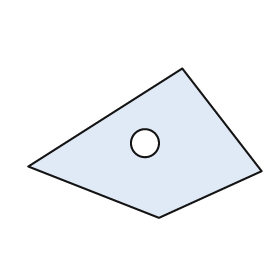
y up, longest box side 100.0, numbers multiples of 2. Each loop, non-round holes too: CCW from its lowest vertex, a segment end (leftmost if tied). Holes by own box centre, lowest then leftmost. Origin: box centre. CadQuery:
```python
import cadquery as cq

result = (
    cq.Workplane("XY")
    .moveTo(6.0, -32.0)
    .lineTo(50.0, -12.0)
    .lineTo(16.0, 32.0)
    .lineTo(-50.0, -10.0)
    .close()
    .moveTo(0.0, 0.0)
    .circle(6.0)
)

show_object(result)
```